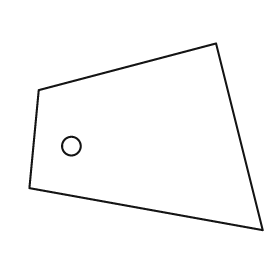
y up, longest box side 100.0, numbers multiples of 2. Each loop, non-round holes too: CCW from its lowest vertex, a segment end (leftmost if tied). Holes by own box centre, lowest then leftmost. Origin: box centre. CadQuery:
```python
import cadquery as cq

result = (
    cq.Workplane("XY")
    .moveTo(50.0, -40.0)
    .lineTo(30.0, 40.0)
    .lineTo(-46.0, 20.0)
    .lineTo(-50.0, -22.0)
    .close()
    .moveTo(-32.0, -4.0)
    .circle(4.0)
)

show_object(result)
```